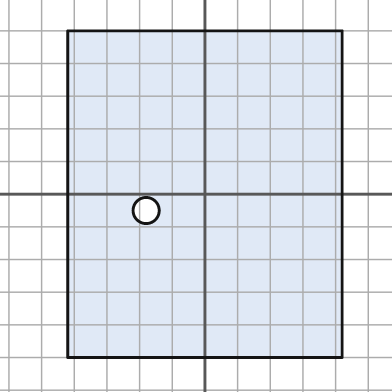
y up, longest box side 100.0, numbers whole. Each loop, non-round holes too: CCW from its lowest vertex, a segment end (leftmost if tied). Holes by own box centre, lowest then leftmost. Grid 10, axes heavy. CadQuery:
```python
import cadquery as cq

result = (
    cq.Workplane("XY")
    .moveTo(-42.0, -50.0)
    .lineTo(42.0, -50.0)
    .lineTo(42.0, 50.0)
    .lineTo(-42.0, 50.0)
    .close()
    .moveTo(-18.0, -5.0)
    .circle(4.0)
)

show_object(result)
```